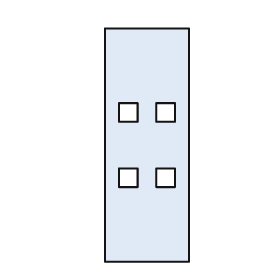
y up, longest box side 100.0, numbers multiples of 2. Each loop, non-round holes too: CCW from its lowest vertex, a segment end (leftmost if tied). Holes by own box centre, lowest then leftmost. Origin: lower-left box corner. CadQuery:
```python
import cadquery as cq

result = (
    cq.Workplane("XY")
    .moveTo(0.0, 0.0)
    .lineTo(36.0, 0.0)
    .lineTo(36.0, 100.0)
    .lineTo(0.0, 100.0)
    .close()
    .moveTo(6.0, 32.0)
    .lineTo(14.0, 32.0)
    .lineTo(14.0, 40.0)
    .lineTo(6.0, 40.0)
    .close()
    .moveTo(22.0, 32.0)
    .lineTo(30.0, 32.0)
    .lineTo(30.0, 40.0)
    .lineTo(22.0, 40.0)
    .close()
    .moveTo(6.0, 60.0)
    .lineTo(14.0, 60.0)
    .lineTo(14.0, 68.0)
    .lineTo(6.0, 68.0)
    .close()
    .moveTo(22.0, 60.0)
    .lineTo(30.0, 60.0)
    .lineTo(30.0, 68.0)
    .lineTo(22.0, 68.0)
    .close()
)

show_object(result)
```